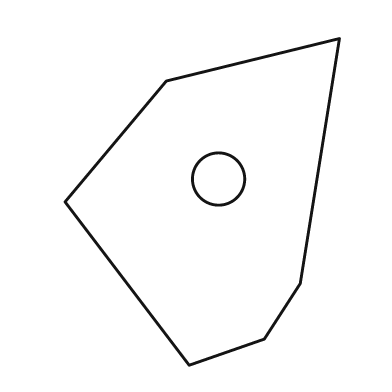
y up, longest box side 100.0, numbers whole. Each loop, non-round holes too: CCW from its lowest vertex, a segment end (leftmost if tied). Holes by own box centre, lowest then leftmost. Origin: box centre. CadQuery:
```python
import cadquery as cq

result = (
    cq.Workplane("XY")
    .moveTo(-4.0, -50.0)
    .lineTo(19.0, -42.0)
    .lineTo(30.0, -25.0)
    .lineTo(42.0, 50.0)
    .lineTo(-11.0, 37.0)
    .lineTo(-42.0, 0.0)
    .close()
    .moveTo(5.0, 7.0)
    .circle(8.0)
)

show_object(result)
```